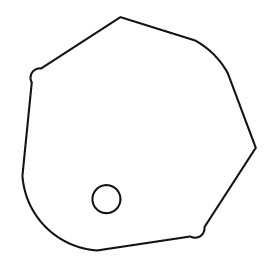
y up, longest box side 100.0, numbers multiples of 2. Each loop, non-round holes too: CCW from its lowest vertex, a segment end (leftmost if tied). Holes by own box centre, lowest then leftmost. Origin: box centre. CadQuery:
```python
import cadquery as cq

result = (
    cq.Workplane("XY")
    .moveTo(-18.0, -50.0)
    .lineTo(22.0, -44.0)
    .threePointArc((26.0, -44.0), (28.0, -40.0))
    .lineTo(50.0, -6.0)
    .lineTo(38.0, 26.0)
    .threePointArc((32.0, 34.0), (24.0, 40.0))
    .lineTo(-8.0, 50.0)
    .lineTo(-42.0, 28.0)
    .threePointArc((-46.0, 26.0), (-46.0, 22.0))
    .lineTo(-50.0, -18.0)
    .threePointArc((-40.0, -40.0), (-18.0, -50.0))
    .close()
    .moveTo(-14.0, -28.0)
    .circle(6.0)
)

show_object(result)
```